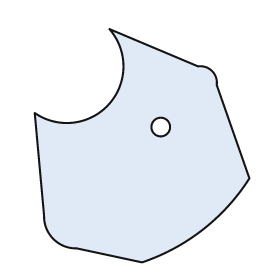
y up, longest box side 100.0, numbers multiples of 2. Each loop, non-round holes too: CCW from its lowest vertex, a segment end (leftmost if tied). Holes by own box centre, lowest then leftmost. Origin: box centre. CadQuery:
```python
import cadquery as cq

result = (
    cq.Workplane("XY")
    .moveTo(0.0, -50.0)
    .threePointArc((26.0, -36.0), (46.0, -14.0))
    .lineTo(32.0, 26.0)
    .threePointArc((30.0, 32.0), (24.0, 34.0))
    .lineTo(-14.0, 50.0)
    .threePointArc((-14.0, 18.0), (-46.0, 14.0))
    .lineTo(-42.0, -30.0)
    .threePointArc((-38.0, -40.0), (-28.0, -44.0))
    .close()
    .moveTo(8.0, 8.0)
    .circle(4.0)
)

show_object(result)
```